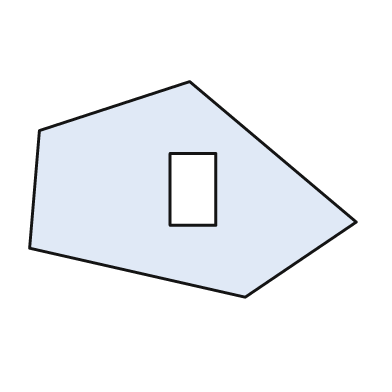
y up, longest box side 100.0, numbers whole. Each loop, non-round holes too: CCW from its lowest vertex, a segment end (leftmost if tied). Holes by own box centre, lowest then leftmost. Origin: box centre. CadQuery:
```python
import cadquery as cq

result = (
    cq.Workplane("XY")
    .moveTo(16.0, -33.0)
    .lineTo(50.0, -10.0)
    .lineTo(-1.0, 33.0)
    .lineTo(-47.0, 18.0)
    .lineTo(-50.0, -18.0)
    .close()
    .moveTo(-7.0, -11.0)
    .lineTo(7.0, -11.0)
    .lineTo(7.0, 11.0)
    .lineTo(-7.0, 11.0)
    .close()
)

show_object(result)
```